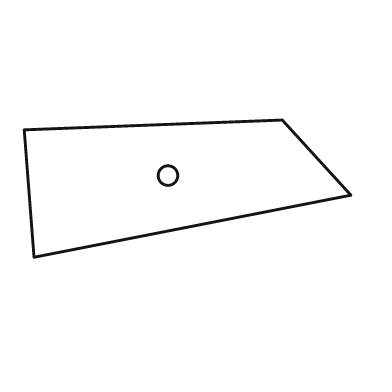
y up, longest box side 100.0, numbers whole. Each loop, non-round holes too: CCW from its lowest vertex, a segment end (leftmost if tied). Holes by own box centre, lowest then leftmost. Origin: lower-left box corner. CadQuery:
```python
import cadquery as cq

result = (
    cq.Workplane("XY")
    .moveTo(3.0, 0.0)
    .lineTo(100.0, 19.0)
    .lineTo(79.0, 42.0)
    .lineTo(0.0, 39.0)
    .close()
    .moveTo(44.0, 25.0)
    .circle(3.0)
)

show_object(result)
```